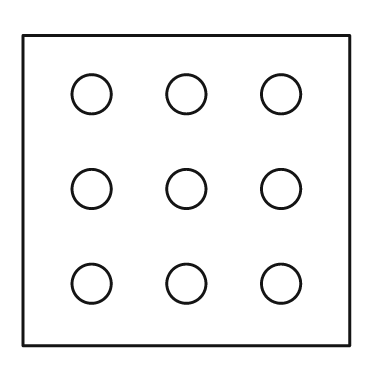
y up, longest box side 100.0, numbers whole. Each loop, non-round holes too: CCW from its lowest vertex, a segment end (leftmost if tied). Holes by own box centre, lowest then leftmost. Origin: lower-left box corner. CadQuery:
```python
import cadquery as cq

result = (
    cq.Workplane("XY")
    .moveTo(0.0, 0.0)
    .lineTo(100.0, 0.0)
    .lineTo(100.0, 95.0)
    .lineTo(0.0, 95.0)
    .close()
    .moveTo(21.0, 19.0)
    .circle(6.0)
    .moveTo(50.0, 19.0)
    .circle(6.0)
    .moveTo(79.0, 19.0)
    .circle(6.0)
    .moveTo(21.0, 48.0)
    .circle(6.0)
    .moveTo(50.0, 48.0)
    .circle(6.0)
    .moveTo(79.0, 48.0)
    .circle(6.0)
    .moveTo(21.0, 77.0)
    .circle(6.0)
    .moveTo(50.0, 77.0)
    .circle(6.0)
    .moveTo(79.0, 77.0)
    .circle(6.0)
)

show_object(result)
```